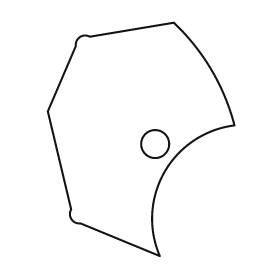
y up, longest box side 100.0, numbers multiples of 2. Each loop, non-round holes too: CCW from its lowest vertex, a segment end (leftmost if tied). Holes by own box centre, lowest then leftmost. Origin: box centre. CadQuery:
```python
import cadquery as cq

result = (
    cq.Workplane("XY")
    .moveTo(8.0, -50.0)
    .threePointArc((10.0, -14.0), (40.0, 6.0))
    .threePointArc((30.0, 30.0), (14.0, 50.0))
    .lineTo(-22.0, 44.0)
    .threePointArc((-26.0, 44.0), (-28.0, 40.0))
    .lineTo(-40.0, 12.0)
    .lineTo(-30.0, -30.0)
    .threePointArc((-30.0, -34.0), (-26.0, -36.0))
    .close()
    .moveTo(6.0, -2.0)
    .circle(6.0)
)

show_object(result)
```